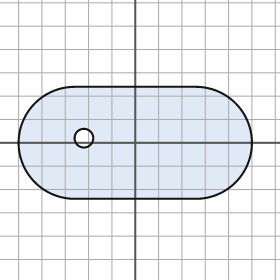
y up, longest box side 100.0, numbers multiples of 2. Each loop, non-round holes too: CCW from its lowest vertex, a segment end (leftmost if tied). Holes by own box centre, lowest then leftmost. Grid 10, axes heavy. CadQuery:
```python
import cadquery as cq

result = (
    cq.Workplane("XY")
    .moveTo(-26.0, -24.0)
    .lineTo(26.0, -24.0)
    .threePointArc((50.0, 0.0), (26.0, 24.0))
    .lineTo(-26.0, 24.0)
    .threePointArc((-50.0, 0.0), (-26.0, -24.0))
    .close()
    .moveTo(-22.0, 2.0)
    .circle(4.0)
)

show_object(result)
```